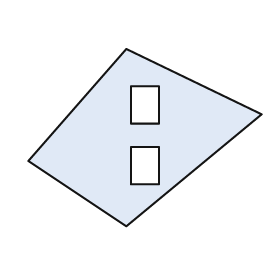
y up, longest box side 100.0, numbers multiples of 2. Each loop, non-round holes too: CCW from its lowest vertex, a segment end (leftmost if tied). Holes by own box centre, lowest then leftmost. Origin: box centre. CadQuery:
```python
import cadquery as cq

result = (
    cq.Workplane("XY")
    .moveTo(-8.0, -38.0)
    .lineTo(50.0, 10.0)
    .lineTo(-8.0, 38.0)
    .lineTo(-50.0, -10.0)
    .close()
    .moveTo(-6.0, -20.0)
    .lineTo(6.0, -20.0)
    .lineTo(6.0, -4.0)
    .lineTo(-6.0, -4.0)
    .close()
    .moveTo(-6.0, 6.0)
    .lineTo(6.0, 6.0)
    .lineTo(6.0, 22.0)
    .lineTo(-6.0, 22.0)
    .close()
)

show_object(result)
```